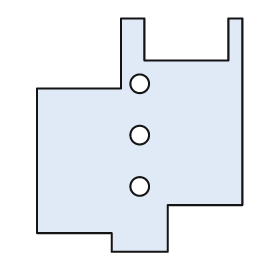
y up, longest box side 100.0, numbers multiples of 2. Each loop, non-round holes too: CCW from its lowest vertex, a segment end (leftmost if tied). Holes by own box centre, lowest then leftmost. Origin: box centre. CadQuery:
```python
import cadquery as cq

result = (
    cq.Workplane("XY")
    .moveTo(-12.0, -50.0)
    .lineTo(12.0, -50.0)
    .lineTo(12.0, -30.0)
    .lineTo(44.0, -30.0)
    .lineTo(44.0, 50.0)
    .lineTo(38.0, 50.0)
    .lineTo(38.0, 32.0)
    .lineTo(2.0, 32.0)
    .lineTo(2.0, 50.0)
    .lineTo(-8.0, 50.0)
    .lineTo(-8.0, 20.0)
    .lineTo(-44.0, 20.0)
    .lineTo(-44.0, -42.0)
    .lineTo(-12.0, -42.0)
    .close()
    .moveTo(0.0, -22.0)
    .circle(4.0)
    .moveTo(0.0, 0.0)
    .circle(4.0)
    .moveTo(0.0, 22.0)
    .circle(4.0)
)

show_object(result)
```